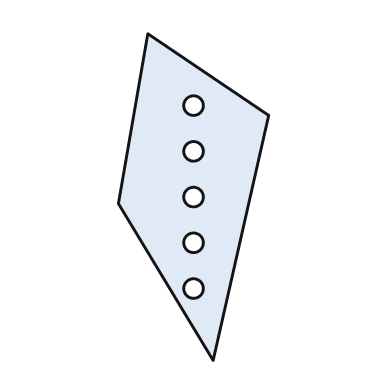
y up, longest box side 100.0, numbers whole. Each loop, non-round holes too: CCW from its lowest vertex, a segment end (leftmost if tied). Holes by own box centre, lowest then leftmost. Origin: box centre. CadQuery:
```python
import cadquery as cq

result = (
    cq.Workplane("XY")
    .moveTo(6.0, -50.0)
    .lineTo(23.0, 25.0)
    .lineTo(-14.0, 50.0)
    .lineTo(-23.0, -2.0)
    .close()
    .moveTo(0.0, -28.0)
    .circle(3.0)
    .moveTo(0.0, -14.0)
    .circle(3.0)
    .moveTo(0.0, 0.0)
    .circle(3.0)
    .moveTo(0.0, 14.0)
    .circle(3.0)
    .moveTo(0.0, 28.0)
    .circle(3.0)
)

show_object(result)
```